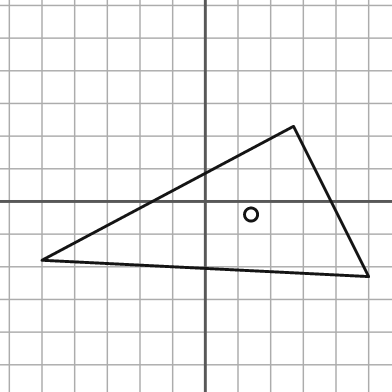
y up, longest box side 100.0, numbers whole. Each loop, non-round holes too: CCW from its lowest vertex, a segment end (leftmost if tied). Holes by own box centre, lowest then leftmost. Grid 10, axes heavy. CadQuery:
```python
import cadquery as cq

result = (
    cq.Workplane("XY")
    .moveTo(50.0, -23.0)
    .lineTo(27.0, 23.0)
    .lineTo(-50.0, -18.0)
    .close()
    .moveTo(14.0, -4.0)
    .circle(2.0)
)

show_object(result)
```